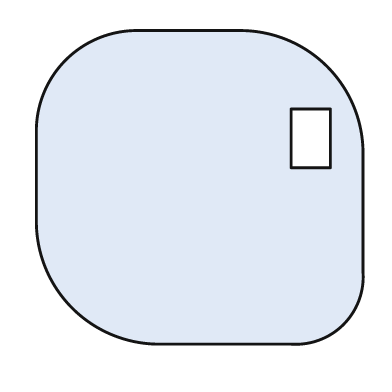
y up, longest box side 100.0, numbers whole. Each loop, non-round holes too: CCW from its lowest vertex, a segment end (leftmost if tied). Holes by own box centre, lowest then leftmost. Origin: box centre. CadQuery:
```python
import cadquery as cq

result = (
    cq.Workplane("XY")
    .moveTo(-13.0, -48.0)
    .lineTo(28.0, -48.0)
    .threePointArc((44.0, -42.0), (50.0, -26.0))
    .lineTo(50.0, 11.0)
    .threePointArc((39.0, 37.0), (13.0, 48.0))
    .lineTo(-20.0, 48.0)
    .threePointArc((-41.0, 39.0), (-50.0, 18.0))
    .lineTo(-50.0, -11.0)
    .threePointArc((-39.0, -37.0), (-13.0, -48.0))
    .close()
    .moveTo(28.0, 6.0)
    .lineTo(40.0, 6.0)
    .lineTo(40.0, 24.0)
    .lineTo(28.0, 24.0)
    .close()
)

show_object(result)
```